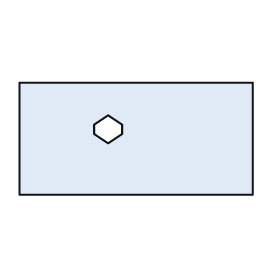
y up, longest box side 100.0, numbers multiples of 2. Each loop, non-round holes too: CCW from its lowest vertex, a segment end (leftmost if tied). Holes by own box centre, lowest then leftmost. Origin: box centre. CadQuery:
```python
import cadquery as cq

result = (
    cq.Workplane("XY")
    .moveTo(-50.0, -24.0)
    .lineTo(50.0, -24.0)
    .lineTo(50.0, 24.0)
    .lineTo(-50.0, 24.0)
    .close()
    .moveTo(-12.0, -2.0)
    .lineTo(-6.0, 2.0)
    .lineTo(-6.0, 6.0)
    .lineTo(-12.0, 10.0)
    .lineTo(-18.0, 6.0)
    .lineTo(-18.0, 2.0)
    .close()
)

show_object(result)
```